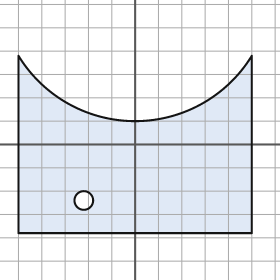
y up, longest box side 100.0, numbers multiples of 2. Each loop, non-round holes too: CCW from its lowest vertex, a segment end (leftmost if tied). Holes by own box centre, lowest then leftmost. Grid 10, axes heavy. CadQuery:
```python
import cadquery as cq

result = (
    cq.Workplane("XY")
    .moveTo(-50.0, -38.0)
    .lineTo(50.0, -38.0)
    .lineTo(50.0, 38.0)
    .threePointArc((0.0, 10.0), (-50.0, 38.0))
    .close()
    .moveTo(-22.0, -24.0)
    .circle(4.0)
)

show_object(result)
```